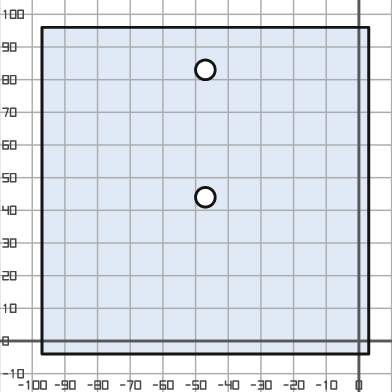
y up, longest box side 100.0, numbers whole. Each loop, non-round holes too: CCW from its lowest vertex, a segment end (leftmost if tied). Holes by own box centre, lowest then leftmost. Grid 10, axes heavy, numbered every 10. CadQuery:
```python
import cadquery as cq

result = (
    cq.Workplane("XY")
    .moveTo(-97.0, -4.0)
    .lineTo(3.0, -4.0)
    .lineTo(3.0, 96.0)
    .lineTo(-97.0, 96.0)
    .close()
    .moveTo(-47.0, 44.0)
    .circle(3.0)
    .moveTo(-47.0, 83.0)
    .circle(3.0)
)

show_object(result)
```